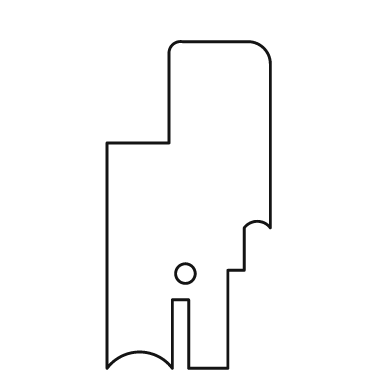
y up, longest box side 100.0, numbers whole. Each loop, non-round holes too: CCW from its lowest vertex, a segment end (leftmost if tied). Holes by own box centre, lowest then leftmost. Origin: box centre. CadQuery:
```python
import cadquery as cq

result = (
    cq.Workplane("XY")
    .moveTo(-25.0, -50.0)
    .threePointArc((-15.0, -45.0), (-5.0, -50.0))
    .lineTo(-5.0, -29.0)
    .lineTo(0.0, -29.0)
    .lineTo(0.0, -50.0)
    .lineTo(12.0, -50.0)
    .lineTo(12.0, -20.0)
    .lineTo(17.0, -20.0)
    .lineTo(17.0, -7.0)
    .threePointArc((21.0, -5.0), (25.0, -7.0))
    .lineTo(25.0, 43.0)
    .threePointArc((23.0, 48.0), (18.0, 50.0))
    .lineTo(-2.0, 50.0)
    .threePointArc((-5.0, 49.0), (-6.0, 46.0))
    .lineTo(-6.0, 19.0)
    .lineTo(-25.0, 19.0)
    .close()
    .moveTo(-1.0, -21.0)
    .circle(3.0)
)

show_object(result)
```